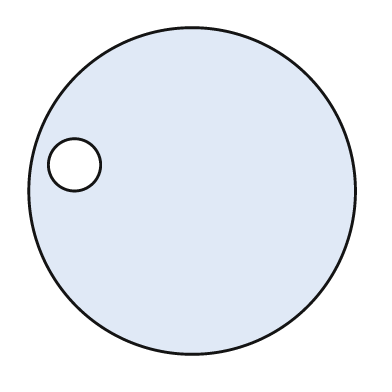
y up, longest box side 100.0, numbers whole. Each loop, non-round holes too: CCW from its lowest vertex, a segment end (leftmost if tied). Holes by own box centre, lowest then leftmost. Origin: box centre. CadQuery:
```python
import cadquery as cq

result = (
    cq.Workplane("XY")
    .moveTo(0.0, 0.0)
    .circle(50.0)
    .moveTo(-36.0, 8.0)
    .circle(8.0)
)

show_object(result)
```